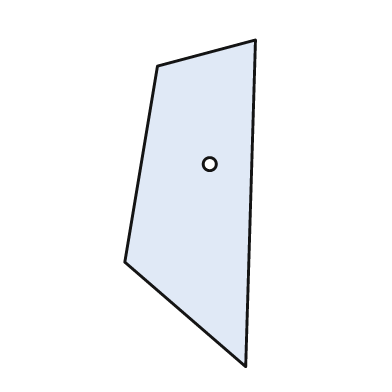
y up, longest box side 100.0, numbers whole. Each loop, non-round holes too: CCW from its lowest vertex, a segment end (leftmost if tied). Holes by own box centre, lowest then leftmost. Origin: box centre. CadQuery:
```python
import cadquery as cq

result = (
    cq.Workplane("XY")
    .moveTo(17.0, -50.0)
    .lineTo(20.0, 50.0)
    .lineTo(-10.0, 42.0)
    .lineTo(-20.0, -18.0)
    .close()
    .moveTo(6.0, 12.0)
    .circle(2.0)
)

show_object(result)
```